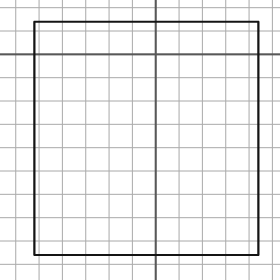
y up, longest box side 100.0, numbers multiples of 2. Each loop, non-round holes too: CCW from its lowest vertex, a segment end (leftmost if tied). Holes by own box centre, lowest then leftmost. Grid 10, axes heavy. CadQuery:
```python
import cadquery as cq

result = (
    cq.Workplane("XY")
    .moveTo(-52.0, -86.0)
    .lineTo(44.0, -86.0)
    .lineTo(44.0, 14.0)
    .lineTo(-52.0, 14.0)
    .close()
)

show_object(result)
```